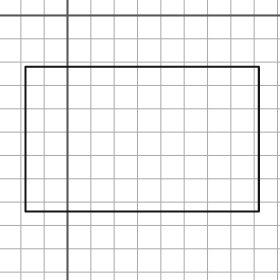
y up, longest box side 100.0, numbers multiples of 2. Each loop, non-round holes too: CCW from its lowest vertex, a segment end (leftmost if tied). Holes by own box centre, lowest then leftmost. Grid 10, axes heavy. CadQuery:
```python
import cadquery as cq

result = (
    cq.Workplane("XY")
    .moveTo(-18.0, -84.0)
    .lineTo(82.0, -84.0)
    .lineTo(82.0, -22.0)
    .lineTo(-18.0, -22.0)
    .close()
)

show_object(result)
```